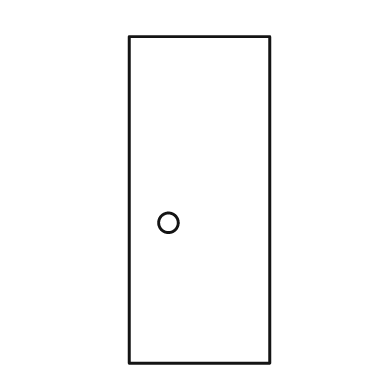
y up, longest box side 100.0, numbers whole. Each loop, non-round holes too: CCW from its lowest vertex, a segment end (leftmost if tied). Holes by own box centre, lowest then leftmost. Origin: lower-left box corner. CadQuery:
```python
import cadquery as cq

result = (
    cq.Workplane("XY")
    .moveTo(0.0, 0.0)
    .lineTo(43.0, 0.0)
    .lineTo(43.0, 100.0)
    .lineTo(0.0, 100.0)
    .close()
    .moveTo(12.0, 43.0)
    .circle(3.0)
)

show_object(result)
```